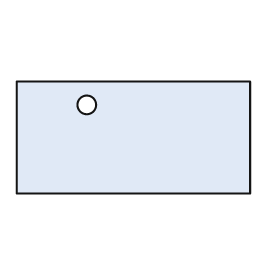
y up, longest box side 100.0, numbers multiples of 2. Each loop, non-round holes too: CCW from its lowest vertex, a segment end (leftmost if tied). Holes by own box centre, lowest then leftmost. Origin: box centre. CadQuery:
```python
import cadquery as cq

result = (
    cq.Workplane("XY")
    .moveTo(-50.0, -24.0)
    .lineTo(50.0, -24.0)
    .lineTo(50.0, 24.0)
    .lineTo(-50.0, 24.0)
    .close()
    .moveTo(-20.0, 14.0)
    .circle(4.0)
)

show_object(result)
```